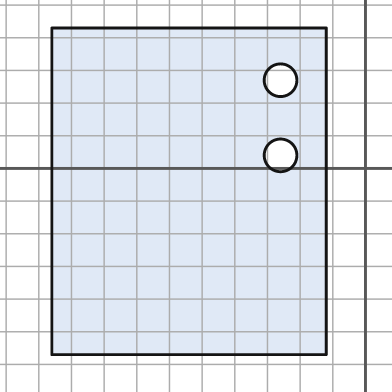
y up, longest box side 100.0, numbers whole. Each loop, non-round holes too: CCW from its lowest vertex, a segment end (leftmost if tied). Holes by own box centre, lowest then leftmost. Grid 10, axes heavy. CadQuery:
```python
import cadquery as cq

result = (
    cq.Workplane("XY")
    .moveTo(-96.0, -57.0)
    .lineTo(-12.0, -57.0)
    .lineTo(-12.0, 43.0)
    .lineTo(-96.0, 43.0)
    .close()
    .moveTo(-26.0, 4.0)
    .circle(5.0)
    .moveTo(-26.0, 27.0)
    .circle(5.0)
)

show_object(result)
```